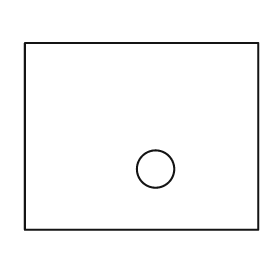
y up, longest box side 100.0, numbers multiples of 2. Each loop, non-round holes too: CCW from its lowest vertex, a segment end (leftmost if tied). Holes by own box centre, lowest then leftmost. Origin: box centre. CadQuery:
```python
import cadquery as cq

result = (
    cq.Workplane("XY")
    .moveTo(-50.0, -40.0)
    .lineTo(50.0, -40.0)
    .lineTo(50.0, 40.0)
    .lineTo(-50.0, 40.0)
    .close()
    .moveTo(6.0, -14.0)
    .circle(8.0)
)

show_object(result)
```